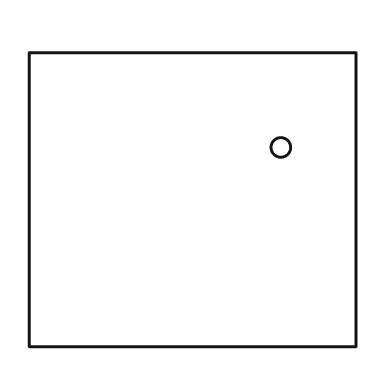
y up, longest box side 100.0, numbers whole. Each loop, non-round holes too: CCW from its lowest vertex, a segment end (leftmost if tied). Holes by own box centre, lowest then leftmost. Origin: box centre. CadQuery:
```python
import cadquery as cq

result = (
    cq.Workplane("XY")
    .moveTo(-50.0, -45.0)
    .lineTo(50.0, -45.0)
    .lineTo(50.0, 45.0)
    .lineTo(-50.0, 45.0)
    .close()
    .moveTo(27.0, 16.0)
    .circle(3.0)
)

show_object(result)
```